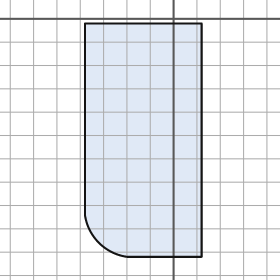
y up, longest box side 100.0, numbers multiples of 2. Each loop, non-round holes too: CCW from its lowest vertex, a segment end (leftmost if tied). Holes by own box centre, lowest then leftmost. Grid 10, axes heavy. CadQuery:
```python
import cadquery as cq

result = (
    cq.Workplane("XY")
    .moveTo(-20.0, -102.0)
    .lineTo(12.0, -102.0)
    .lineTo(12.0, -2.0)
    .lineTo(-38.0, -2.0)
    .lineTo(-38.0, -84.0)
    .threePointArc((-32.0, -96.0), (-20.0, -102.0))
    .close()
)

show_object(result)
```